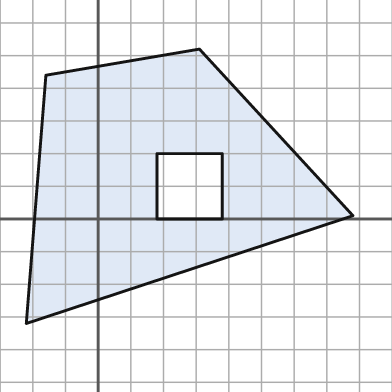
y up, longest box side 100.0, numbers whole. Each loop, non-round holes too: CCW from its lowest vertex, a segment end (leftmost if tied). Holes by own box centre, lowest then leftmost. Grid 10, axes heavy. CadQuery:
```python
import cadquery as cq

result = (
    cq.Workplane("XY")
    .moveTo(-22.0, -32.0)
    .lineTo(78.0, 1.0)
    .lineTo(31.0, 52.0)
    .lineTo(-16.0, 44.0)
    .close()
    .moveTo(18.0, 0.0)
    .lineTo(38.0, 0.0)
    .lineTo(38.0, 20.0)
    .lineTo(18.0, 20.0)
    .close()
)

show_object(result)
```